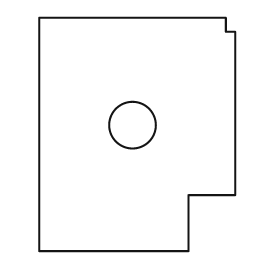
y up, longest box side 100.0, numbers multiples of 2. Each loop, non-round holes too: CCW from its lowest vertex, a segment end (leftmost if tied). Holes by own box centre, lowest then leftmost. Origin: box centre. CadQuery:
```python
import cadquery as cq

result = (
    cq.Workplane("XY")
    .moveTo(-42.0, -50.0)
    .lineTo(22.0, -50.0)
    .lineTo(22.0, -26.0)
    .lineTo(42.0, -26.0)
    .lineTo(42.0, 44.0)
    .lineTo(38.0, 44.0)
    .lineTo(38.0, 50.0)
    .lineTo(-42.0, 50.0)
    .close()
    .moveTo(-2.0, 4.0)
    .circle(10.0)
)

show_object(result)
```